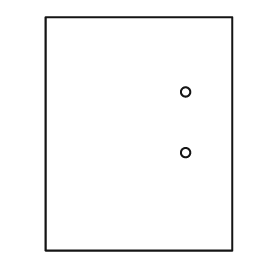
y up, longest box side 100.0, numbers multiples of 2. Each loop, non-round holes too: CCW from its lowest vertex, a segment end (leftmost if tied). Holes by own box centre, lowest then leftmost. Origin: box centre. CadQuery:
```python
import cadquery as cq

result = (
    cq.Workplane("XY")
    .moveTo(-40.0, -50.0)
    .lineTo(40.0, -50.0)
    .lineTo(40.0, 50.0)
    .lineTo(-40.0, 50.0)
    .close()
    .moveTo(20.0, -8.0)
    .circle(2.0)
    .moveTo(20.0, 18.0)
    .circle(2.0)
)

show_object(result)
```